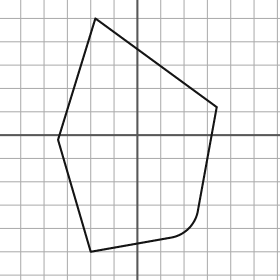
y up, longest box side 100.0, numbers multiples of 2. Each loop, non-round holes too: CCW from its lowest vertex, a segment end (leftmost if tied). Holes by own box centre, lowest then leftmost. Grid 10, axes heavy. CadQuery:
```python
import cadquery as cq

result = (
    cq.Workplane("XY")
    .moveTo(-20.0, -50.0)
    .lineTo(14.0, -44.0)
    .threePointArc((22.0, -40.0), (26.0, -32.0))
    .lineTo(34.0, 12.0)
    .lineTo(-18.0, 50.0)
    .lineTo(-34.0, -2.0)
    .close()
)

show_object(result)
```